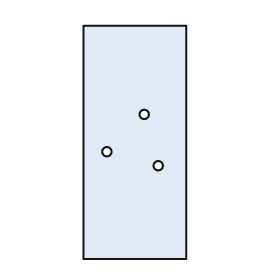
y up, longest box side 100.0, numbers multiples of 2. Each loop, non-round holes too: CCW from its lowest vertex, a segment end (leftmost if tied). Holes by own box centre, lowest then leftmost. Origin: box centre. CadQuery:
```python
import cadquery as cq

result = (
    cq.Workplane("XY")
    .moveTo(-22.0, -50.0)
    .lineTo(22.0, -50.0)
    .lineTo(22.0, 50.0)
    .lineTo(-22.0, 50.0)
    .close()
    .moveTo(10.0, -10.0)
    .circle(2.0)
    .moveTo(-12.0, -4.0)
    .circle(2.0)
    .moveTo(4.0, 12.0)
    .circle(2.0)
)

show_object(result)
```